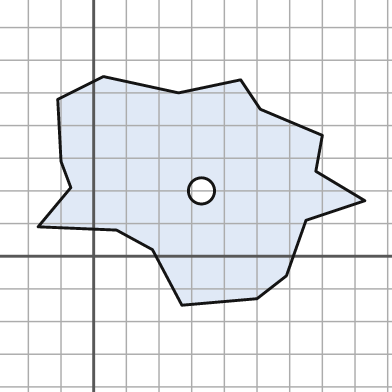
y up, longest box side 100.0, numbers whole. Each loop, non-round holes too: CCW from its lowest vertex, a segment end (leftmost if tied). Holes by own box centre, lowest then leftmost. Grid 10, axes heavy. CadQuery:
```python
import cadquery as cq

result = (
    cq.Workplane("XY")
    .moveTo(27.0, -15.0)
    .lineTo(50.0, -13.0)
    .lineTo(59.0, -6.0)
    .lineTo(65.0, 11.0)
    .lineTo(83.0, 17.0)
    .lineTo(68.0, 26.0)
    .lineTo(70.0, 37.0)
    .lineTo(51.0, 45.0)
    .lineTo(45.0, 54.0)
    .lineTo(26.0, 50.0)
    .lineTo(3.0, 55.0)
    .lineTo(-11.0, 48.0)
    .lineTo(-10.0, 29.0)
    .lineTo(-7.0, 21.0)
    .lineTo(-17.0, 9.0)
    .lineTo(7.0, 8.0)
    .lineTo(18.0, 2.0)
    .close()
    .moveTo(33.0, 20.0)
    .circle(4.0)
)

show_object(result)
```